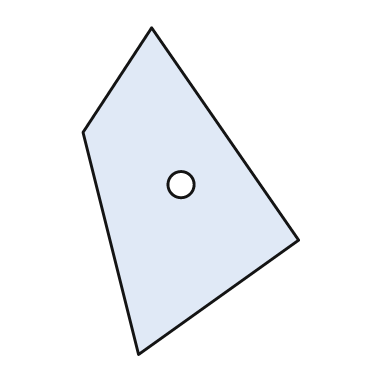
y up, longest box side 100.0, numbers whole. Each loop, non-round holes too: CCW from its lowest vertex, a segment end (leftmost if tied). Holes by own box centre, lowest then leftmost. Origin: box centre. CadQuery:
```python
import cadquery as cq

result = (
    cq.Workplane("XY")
    .moveTo(-16.0, -50.0)
    .lineTo(33.0, -15.0)
    .lineTo(-12.0, 50.0)
    .lineTo(-33.0, 18.0)
    .close()
    .moveTo(-3.0, 2.0)
    .circle(4.0)
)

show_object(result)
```